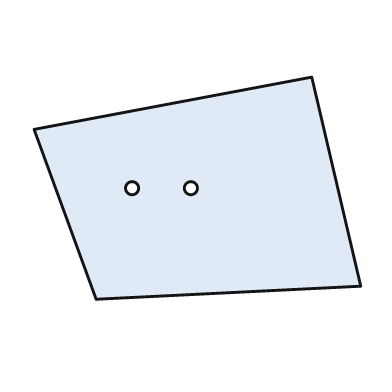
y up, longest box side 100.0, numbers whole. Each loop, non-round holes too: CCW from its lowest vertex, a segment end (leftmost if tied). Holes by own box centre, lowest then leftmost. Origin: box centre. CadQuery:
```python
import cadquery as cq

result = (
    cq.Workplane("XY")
    .moveTo(-31.0, -34.0)
    .lineTo(50.0, -30.0)
    .lineTo(35.0, 34.0)
    .lineTo(-50.0, 18.0)
    .close()
    .moveTo(-20.0, 0.0)
    .circle(2.0)
    .moveTo(-2.0, 0.0)
    .circle(2.0)
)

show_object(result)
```